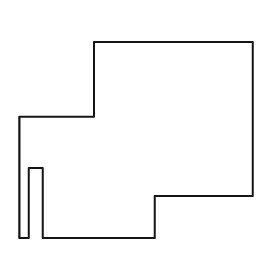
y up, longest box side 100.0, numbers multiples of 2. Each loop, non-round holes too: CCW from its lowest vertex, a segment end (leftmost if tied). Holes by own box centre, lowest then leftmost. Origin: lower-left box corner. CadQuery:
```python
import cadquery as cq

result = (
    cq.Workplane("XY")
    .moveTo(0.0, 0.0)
    .lineTo(4.0, 0.0)
    .lineTo(4.0, 30.0)
    .lineTo(10.0, 30.0)
    .lineTo(10.0, 0.0)
    .lineTo(58.0, 0.0)
    .lineTo(58.0, 18.0)
    .lineTo(100.0, 18.0)
    .lineTo(100.0, 84.0)
    .lineTo(32.0, 84.0)
    .lineTo(32.0, 52.0)
    .lineTo(0.0, 52.0)
    .close()
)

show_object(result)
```